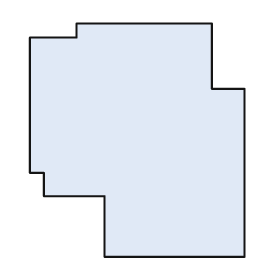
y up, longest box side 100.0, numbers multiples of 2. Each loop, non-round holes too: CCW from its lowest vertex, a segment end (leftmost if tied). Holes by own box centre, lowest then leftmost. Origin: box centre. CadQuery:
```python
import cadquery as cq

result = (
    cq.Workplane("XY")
    .moveTo(-14.0, -50.0)
    .lineTo(46.0, -50.0)
    .lineTo(46.0, 22.0)
    .lineTo(32.0, 22.0)
    .lineTo(32.0, 50.0)
    .lineTo(-26.0, 50.0)
    .lineTo(-26.0, 44.0)
    .lineTo(-46.0, 44.0)
    .lineTo(-46.0, -14.0)
    .lineTo(-40.0, -14.0)
    .lineTo(-40.0, -24.0)
    .lineTo(-14.0, -24.0)
    .close()
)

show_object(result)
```